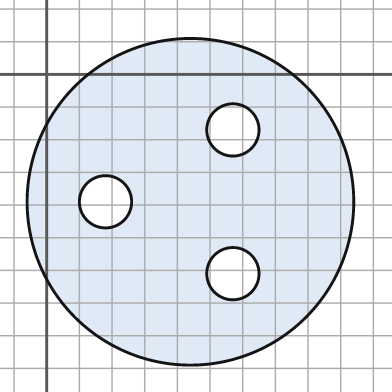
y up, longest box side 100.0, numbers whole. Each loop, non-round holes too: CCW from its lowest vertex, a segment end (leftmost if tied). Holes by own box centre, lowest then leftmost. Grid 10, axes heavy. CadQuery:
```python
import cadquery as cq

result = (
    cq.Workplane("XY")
    .moveTo(44.0, -39.0)
    .circle(50.0)
    .moveTo(57.0, -61.0)
    .circle(8.0)
    .moveTo(18.0, -39.0)
    .circle(8.0)
    .moveTo(57.0, -17.0)
    .circle(8.0)
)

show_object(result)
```